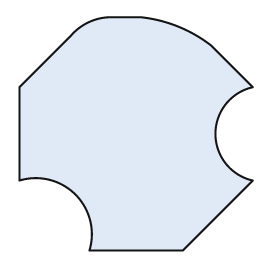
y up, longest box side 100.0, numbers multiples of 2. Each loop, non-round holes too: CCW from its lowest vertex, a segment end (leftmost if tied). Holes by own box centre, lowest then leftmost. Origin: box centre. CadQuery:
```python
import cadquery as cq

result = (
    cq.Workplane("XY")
    .moveTo(-20.0, -50.0)
    .lineTo(20.0, -50.0)
    .lineTo(50.0, -20.0)
    .threePointArc((34.0, 0.0), (50.0, 20.0))
    .lineTo(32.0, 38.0)
    .threePointArc((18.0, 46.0), (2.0, 50.0))
    .lineTo(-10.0, 50.0)
    .threePointArc((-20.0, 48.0), (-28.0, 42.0))
    .lineTo(-50.0, 20.0)
    .lineTo(-50.0, -20.0)
    .threePointArc((-26.0, -26.0), (-20.0, -50.0))
    .close()
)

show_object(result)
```